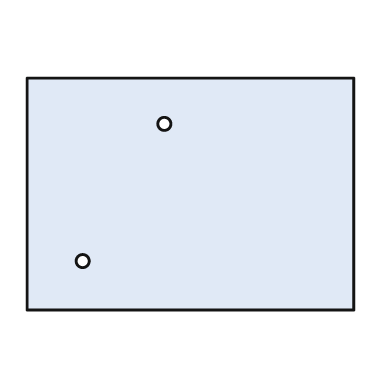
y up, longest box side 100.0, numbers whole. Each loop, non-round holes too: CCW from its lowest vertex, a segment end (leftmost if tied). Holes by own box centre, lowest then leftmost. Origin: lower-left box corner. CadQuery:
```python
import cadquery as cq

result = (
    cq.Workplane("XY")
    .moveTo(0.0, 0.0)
    .lineTo(100.0, 0.0)
    .lineTo(100.0, 71.0)
    .lineTo(0.0, 71.0)
    .close()
    .moveTo(17.0, 15.0)
    .circle(2.0)
    .moveTo(42.0, 57.0)
    .circle(2.0)
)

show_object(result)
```